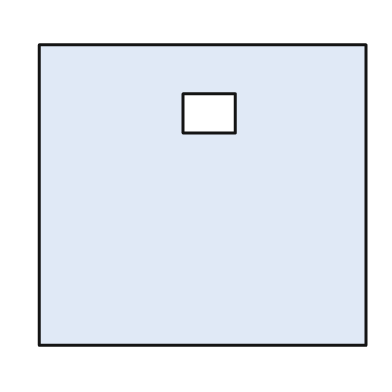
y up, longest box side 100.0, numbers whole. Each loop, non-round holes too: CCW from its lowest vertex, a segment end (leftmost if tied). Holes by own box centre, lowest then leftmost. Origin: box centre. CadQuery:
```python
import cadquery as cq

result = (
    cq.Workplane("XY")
    .moveTo(-50.0, -46.0)
    .lineTo(50.0, -46.0)
    .lineTo(50.0, 46.0)
    .lineTo(-50.0, 46.0)
    .close()
    .moveTo(-6.0, 19.0)
    .lineTo(10.0, 19.0)
    .lineTo(10.0, 31.0)
    .lineTo(-6.0, 31.0)
    .close()
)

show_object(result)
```